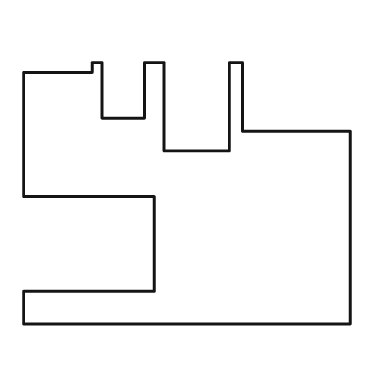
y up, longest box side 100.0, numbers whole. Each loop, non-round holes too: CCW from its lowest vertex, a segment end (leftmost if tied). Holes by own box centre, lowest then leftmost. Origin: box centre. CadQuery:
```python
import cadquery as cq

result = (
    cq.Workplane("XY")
    .moveTo(-50.0, -40.0)
    .lineTo(50.0, -40.0)
    .lineTo(50.0, 19.0)
    .lineTo(17.0, 19.0)
    .lineTo(17.0, 40.0)
    .lineTo(13.0, 40.0)
    .lineTo(13.0, 13.0)
    .lineTo(-7.0, 13.0)
    .lineTo(-7.0, 40.0)
    .lineTo(-13.0, 40.0)
    .lineTo(-13.0, 23.0)
    .lineTo(-26.0, 23.0)
    .lineTo(-26.0, 40.0)
    .lineTo(-29.0, 40.0)
    .lineTo(-29.0, 37.0)
    .lineTo(-50.0, 37.0)
    .lineTo(-50.0, -1.0)
    .lineTo(-10.0, -1.0)
    .lineTo(-10.0, -30.0)
    .lineTo(-50.0, -30.0)
    .close()
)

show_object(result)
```